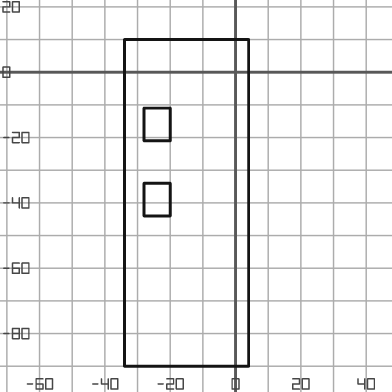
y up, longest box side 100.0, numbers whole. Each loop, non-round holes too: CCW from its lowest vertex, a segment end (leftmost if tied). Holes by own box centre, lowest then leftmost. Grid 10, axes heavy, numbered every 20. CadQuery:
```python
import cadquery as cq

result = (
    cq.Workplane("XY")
    .moveTo(-34.0, -90.0)
    .lineTo(4.0, -90.0)
    .lineTo(4.0, 10.0)
    .lineTo(-34.0, 10.0)
    .close()
    .moveTo(-28.0, -44.0)
    .lineTo(-20.0, -44.0)
    .lineTo(-20.0, -34.0)
    .lineTo(-28.0, -34.0)
    .close()
    .moveTo(-28.0, -21.0)
    .lineTo(-20.0, -21.0)
    .lineTo(-20.0, -11.0)
    .lineTo(-28.0, -11.0)
    .close()
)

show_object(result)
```